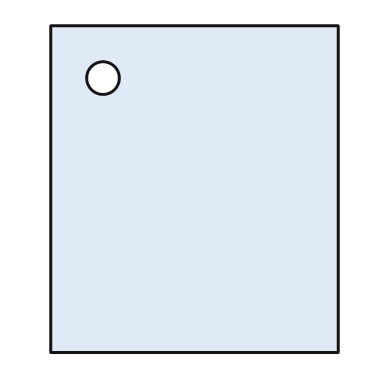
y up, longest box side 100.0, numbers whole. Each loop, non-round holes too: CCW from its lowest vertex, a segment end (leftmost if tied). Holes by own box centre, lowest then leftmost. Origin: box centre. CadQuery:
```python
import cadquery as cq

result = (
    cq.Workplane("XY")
    .moveTo(-44.0, -50.0)
    .lineTo(44.0, -50.0)
    .lineTo(44.0, 50.0)
    .lineTo(-44.0, 50.0)
    .close()
    .moveTo(-28.0, 34.0)
    .circle(5.0)
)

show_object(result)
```